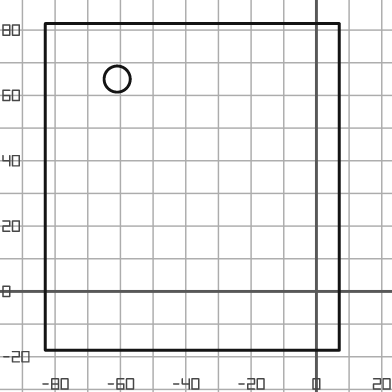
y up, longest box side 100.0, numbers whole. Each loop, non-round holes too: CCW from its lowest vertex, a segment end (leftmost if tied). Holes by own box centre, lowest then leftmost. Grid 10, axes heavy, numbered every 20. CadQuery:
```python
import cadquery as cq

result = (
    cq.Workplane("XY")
    .moveTo(-83.0, -18.0)
    .lineTo(7.0, -18.0)
    .lineTo(7.0, 82.0)
    .lineTo(-83.0, 82.0)
    .close()
    .moveTo(-61.0, 65.0)
    .circle(4.0)
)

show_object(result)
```